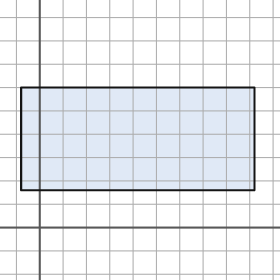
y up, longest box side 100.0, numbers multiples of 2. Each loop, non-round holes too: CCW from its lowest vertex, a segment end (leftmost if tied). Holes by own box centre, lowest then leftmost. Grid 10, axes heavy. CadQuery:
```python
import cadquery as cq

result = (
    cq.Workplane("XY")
    .moveTo(-8.0, 16.0)
    .lineTo(92.0, 16.0)
    .lineTo(92.0, 60.0)
    .lineTo(-8.0, 60.0)
    .close()
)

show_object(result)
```